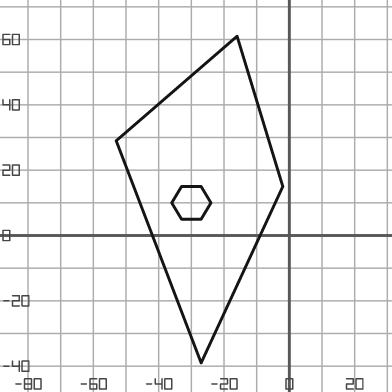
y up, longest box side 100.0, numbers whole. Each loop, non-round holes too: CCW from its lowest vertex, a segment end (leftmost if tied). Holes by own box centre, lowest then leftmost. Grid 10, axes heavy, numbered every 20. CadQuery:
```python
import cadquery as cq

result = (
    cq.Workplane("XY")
    .moveTo(-27.0, -39.0)
    .lineTo(-2.0, 15.0)
    .lineTo(-16.0, 61.0)
    .lineTo(-53.0, 29.0)
    .close()
    .moveTo(-33.0, 5.0)
    .lineTo(-27.0, 5.0)
    .lineTo(-24.0, 10.0)
    .lineTo(-27.0, 15.0)
    .lineTo(-33.0, 15.0)
    .lineTo(-36.0, 10.0)
    .close()
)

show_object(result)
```